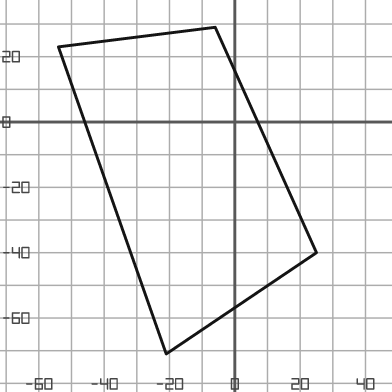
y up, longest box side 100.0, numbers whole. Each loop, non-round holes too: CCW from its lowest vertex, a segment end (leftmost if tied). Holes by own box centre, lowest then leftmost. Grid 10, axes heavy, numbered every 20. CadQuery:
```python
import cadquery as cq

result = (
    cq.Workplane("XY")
    .moveTo(-21.0, -71.0)
    .lineTo(25.0, -40.0)
    .lineTo(-6.0, 29.0)
    .lineTo(-54.0, 23.0)
    .close()
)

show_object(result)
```